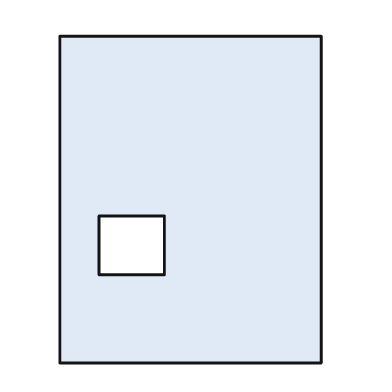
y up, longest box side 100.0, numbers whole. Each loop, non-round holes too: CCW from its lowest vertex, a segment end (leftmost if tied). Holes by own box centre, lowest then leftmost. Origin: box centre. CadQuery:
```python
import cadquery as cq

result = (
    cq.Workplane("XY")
    .moveTo(-40.0, -50.0)
    .lineTo(40.0, -50.0)
    .lineTo(40.0, 50.0)
    .lineTo(-40.0, 50.0)
    .close()
    .moveTo(-28.0, -23.0)
    .lineTo(-8.0, -23.0)
    .lineTo(-8.0, -5.0)
    .lineTo(-28.0, -5.0)
    .close()
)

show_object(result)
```